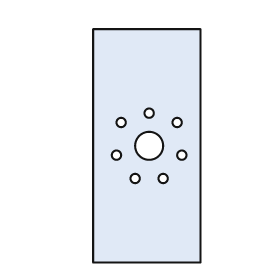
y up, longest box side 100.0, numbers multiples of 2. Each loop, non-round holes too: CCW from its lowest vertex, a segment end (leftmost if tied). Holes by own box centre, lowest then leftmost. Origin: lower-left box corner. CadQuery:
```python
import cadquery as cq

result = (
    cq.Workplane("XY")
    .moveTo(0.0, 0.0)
    .lineTo(46.0, 0.0)
    .lineTo(46.0, 100.0)
    .lineTo(0.0, 100.0)
    .close()
    .moveTo(18.0, 36.0)
    .circle(2.0)
    .moveTo(30.0, 36.0)
    .circle(2.0)
    .moveTo(10.0, 46.0)
    .circle(2.0)
    .moveTo(38.0, 46.0)
    .circle(2.0)
    .moveTo(24.0, 50.0)
    .circle(6.0)
    .moveTo(12.0, 60.0)
    .circle(2.0)
    .moveTo(36.0, 60.0)
    .circle(2.0)
    .moveTo(24.0, 64.0)
    .circle(2.0)
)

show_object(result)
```